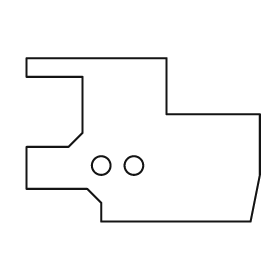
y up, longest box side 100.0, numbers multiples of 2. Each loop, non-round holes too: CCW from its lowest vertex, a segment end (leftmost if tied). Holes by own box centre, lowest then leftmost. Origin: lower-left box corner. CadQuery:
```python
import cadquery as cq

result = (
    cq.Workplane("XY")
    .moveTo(32.0, 0.0)
    .lineTo(96.0, 0.0)
    .lineTo(100.0, 20.0)
    .lineTo(100.0, 46.0)
    .lineTo(60.0, 46.0)
    .lineTo(60.0, 70.0)
    .lineTo(0.0, 70.0)
    .lineTo(0.0, 62.0)
    .lineTo(24.0, 62.0)
    .lineTo(24.0, 38.0)
    .lineTo(18.0, 32.0)
    .lineTo(0.0, 32.0)
    .lineTo(0.0, 14.0)
    .lineTo(26.0, 14.0)
    .lineTo(32.0, 8.0)
    .close()
    .moveTo(32.0, 24.0)
    .circle(4.0)
    .moveTo(46.0, 24.0)
    .circle(4.0)
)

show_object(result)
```